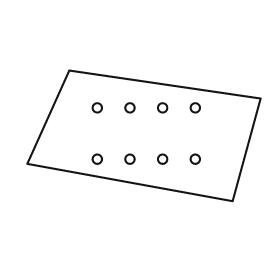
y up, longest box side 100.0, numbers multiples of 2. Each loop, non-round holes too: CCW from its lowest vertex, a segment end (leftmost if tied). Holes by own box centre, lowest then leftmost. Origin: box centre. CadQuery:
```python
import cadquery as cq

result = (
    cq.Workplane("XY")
    .moveTo(38.0, -28.0)
    .lineTo(50.0, 16.0)
    .lineTo(-32.0, 28.0)
    .lineTo(-50.0, -12.0)
    .close()
    .moveTo(-20.0, -10.0)
    .circle(2.0)
    .moveTo(-6.0, -10.0)
    .circle(2.0)
    .moveTo(8.0, -10.0)
    .circle(2.0)
    .moveTo(22.0, -10.0)
    .circle(2.0)
    .moveTo(-20.0, 12.0)
    .circle(2.0)
    .moveTo(-6.0, 12.0)
    .circle(2.0)
    .moveTo(8.0, 12.0)
    .circle(2.0)
    .moveTo(22.0, 12.0)
    .circle(2.0)
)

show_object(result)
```